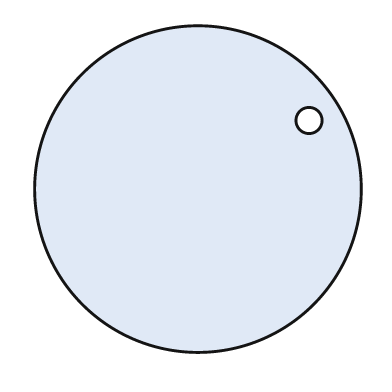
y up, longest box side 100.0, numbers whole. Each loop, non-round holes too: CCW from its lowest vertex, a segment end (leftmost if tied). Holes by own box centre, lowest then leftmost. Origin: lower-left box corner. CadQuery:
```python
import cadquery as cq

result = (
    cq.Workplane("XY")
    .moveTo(50.0, 50.0)
    .circle(50.0)
    .moveTo(84.0, 71.0)
    .circle(4.0)
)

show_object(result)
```